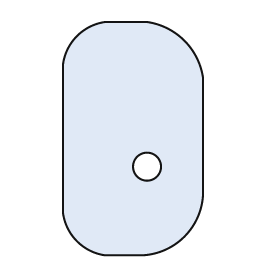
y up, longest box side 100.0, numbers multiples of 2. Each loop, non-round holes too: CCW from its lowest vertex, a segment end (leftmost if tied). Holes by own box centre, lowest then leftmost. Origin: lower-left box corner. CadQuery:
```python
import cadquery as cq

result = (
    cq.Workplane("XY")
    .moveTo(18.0, 0.0)
    .lineTo(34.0, 0.0)
    .threePointArc((52.0, 8.0), (60.0, 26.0))
    .lineTo(60.0, 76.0)
    .threePointArc((52.0, 92.0), (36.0, 100.0))
    .lineTo(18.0, 100.0)
    .threePointArc((6.0, 94.0), (0.0, 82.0))
    .lineTo(0.0, 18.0)
    .threePointArc((6.0, 6.0), (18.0, 0.0))
    .close()
    .moveTo(36.0, 38.0)
    .circle(6.0)
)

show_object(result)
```